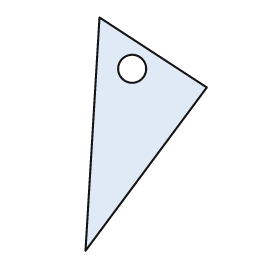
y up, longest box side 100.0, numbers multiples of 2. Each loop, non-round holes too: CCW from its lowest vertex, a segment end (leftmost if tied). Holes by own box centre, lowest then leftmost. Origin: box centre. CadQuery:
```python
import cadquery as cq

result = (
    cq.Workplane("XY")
    .moveTo(-26.0, -50.0)
    .lineTo(26.0, 20.0)
    .lineTo(-20.0, 50.0)
    .close()
    .moveTo(-6.0, 28.0)
    .circle(6.0)
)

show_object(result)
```